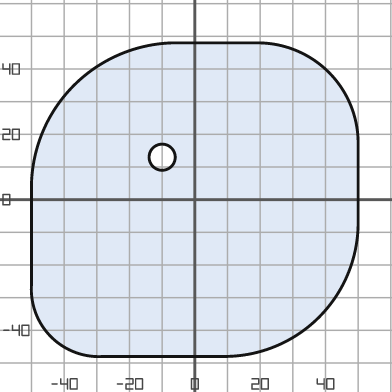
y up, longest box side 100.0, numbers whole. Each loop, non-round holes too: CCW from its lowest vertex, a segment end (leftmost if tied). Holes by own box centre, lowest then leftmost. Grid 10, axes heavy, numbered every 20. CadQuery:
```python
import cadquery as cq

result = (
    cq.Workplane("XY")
    .moveTo(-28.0, -48.0)
    .lineTo(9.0, -48.0)
    .threePointArc((38.0, -36.0), (50.0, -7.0))
    .lineTo(50.0, 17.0)
    .threePointArc((41.0, 39.0), (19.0, 48.0))
    .lineTo(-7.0, 48.0)
    .threePointArc((-37.0, 35.0), (-50.0, 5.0))
    .lineTo(-50.0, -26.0)
    .threePointArc((-44.0, -42.0), (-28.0, -48.0))
    .close()
    .moveTo(-10.0, 13.0)
    .circle(4.0)
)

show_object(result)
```